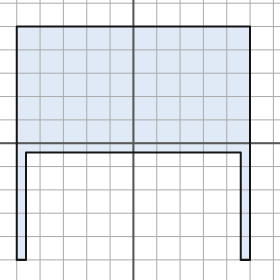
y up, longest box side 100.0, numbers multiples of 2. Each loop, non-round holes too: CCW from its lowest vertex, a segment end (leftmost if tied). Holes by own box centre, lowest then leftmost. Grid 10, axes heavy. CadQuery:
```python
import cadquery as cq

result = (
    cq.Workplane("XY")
    .moveTo(-50.0, -50.0)
    .lineTo(-46.0, -50.0)
    .lineTo(-46.0, -4.0)
    .lineTo(46.0, -4.0)
    .lineTo(46.0, -50.0)
    .lineTo(50.0, -50.0)
    .lineTo(50.0, 50.0)
    .lineTo(-50.0, 50.0)
    .close()
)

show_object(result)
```